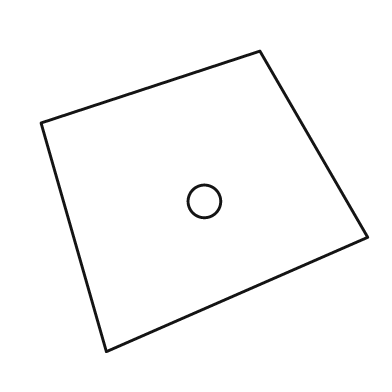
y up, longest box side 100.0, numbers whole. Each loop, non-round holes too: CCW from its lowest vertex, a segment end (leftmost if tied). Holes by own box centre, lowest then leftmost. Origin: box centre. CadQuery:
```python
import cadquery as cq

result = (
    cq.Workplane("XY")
    .moveTo(-30.0, -46.0)
    .lineTo(50.0, -11.0)
    .lineTo(17.0, 46.0)
    .lineTo(-50.0, 24.0)
    .close()
    .moveTo(0.0, 0.0)
    .circle(5.0)
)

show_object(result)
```